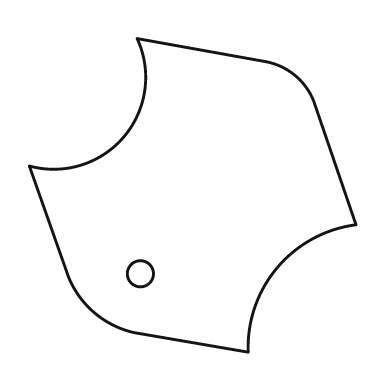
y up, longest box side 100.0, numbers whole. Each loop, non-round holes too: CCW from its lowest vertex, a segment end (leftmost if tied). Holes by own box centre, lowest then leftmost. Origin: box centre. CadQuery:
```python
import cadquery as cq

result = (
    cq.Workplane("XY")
    .moveTo(17.0, -48.0)
    .threePointArc((26.0, -22.0), (50.0, -9.0))
    .lineTo(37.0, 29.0)
    .threePointArc((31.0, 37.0), (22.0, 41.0))
    .lineTo(-17.0, 48.0)
    .threePointArc((-21.0, 18.0), (-50.0, 9.0))
    .lineTo(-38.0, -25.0)
    .threePointArc((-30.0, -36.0), (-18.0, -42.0))
    .close()
    .moveTo(-16.0, -24.0)
    .circle(4.0)
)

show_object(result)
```